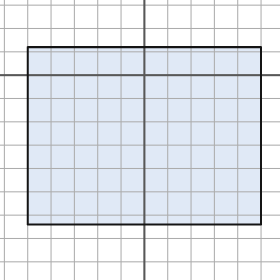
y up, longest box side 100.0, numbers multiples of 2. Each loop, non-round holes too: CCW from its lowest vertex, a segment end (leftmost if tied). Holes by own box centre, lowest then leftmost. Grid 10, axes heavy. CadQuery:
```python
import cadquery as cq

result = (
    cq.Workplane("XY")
    .moveTo(-50.0, -64.0)
    .lineTo(50.0, -64.0)
    .lineTo(50.0, 12.0)
    .lineTo(-50.0, 12.0)
    .close()
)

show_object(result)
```